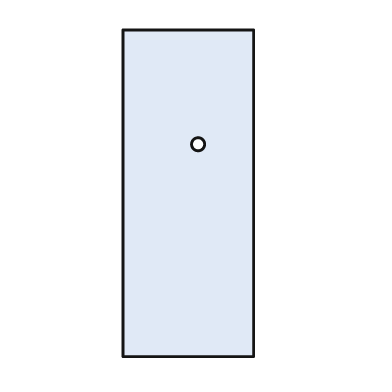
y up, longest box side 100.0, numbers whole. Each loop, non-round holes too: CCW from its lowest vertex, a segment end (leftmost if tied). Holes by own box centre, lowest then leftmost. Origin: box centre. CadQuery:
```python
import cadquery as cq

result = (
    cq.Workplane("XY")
    .moveTo(-20.0, -50.0)
    .lineTo(20.0, -50.0)
    .lineTo(20.0, 50.0)
    .lineTo(-20.0, 50.0)
    .close()
    .moveTo(3.0, 15.0)
    .circle(2.0)
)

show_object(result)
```